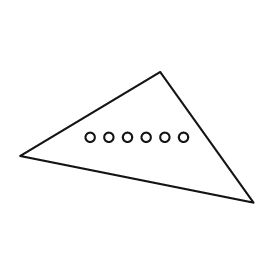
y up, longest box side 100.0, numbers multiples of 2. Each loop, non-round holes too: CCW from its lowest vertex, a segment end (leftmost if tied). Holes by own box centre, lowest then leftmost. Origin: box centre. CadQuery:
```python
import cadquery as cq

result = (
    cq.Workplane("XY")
    .moveTo(50.0, -28.0)
    .lineTo(10.0, 28.0)
    .lineTo(-50.0, -8.0)
    .close()
    .moveTo(-20.0, 0.0)
    .circle(2.0)
    .moveTo(-12.0, 0.0)
    .circle(2.0)
    .moveTo(-4.0, 0.0)
    .circle(2.0)
    .moveTo(4.0, 0.0)
    .circle(2.0)
    .moveTo(12.0, 0.0)
    .circle(2.0)
    .moveTo(20.0, 0.0)
    .circle(2.0)
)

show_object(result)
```